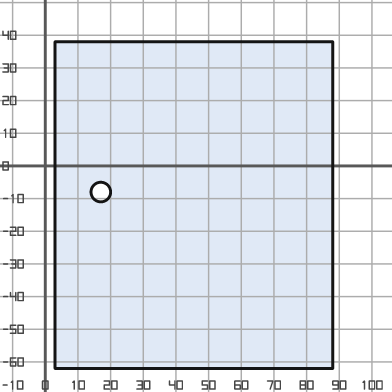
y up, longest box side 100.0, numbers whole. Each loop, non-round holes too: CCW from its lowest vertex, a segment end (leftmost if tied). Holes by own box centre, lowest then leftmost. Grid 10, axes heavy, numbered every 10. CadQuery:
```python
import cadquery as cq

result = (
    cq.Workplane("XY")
    .moveTo(3.0, -62.0)
    .lineTo(88.0, -62.0)
    .lineTo(88.0, 38.0)
    .lineTo(3.0, 38.0)
    .close()
    .moveTo(17.0, -8.0)
    .circle(3.0)
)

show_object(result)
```